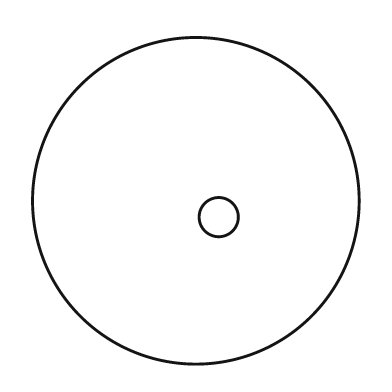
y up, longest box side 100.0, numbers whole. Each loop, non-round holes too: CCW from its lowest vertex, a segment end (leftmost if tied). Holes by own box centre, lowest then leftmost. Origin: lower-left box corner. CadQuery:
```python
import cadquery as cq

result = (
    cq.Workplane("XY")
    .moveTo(50.0, 50.0)
    .circle(50.0)
    .moveTo(57.0, 45.0)
    .circle(6.0)
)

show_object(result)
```